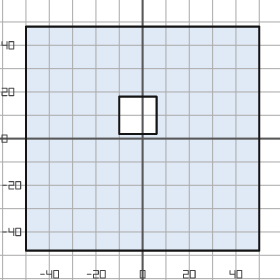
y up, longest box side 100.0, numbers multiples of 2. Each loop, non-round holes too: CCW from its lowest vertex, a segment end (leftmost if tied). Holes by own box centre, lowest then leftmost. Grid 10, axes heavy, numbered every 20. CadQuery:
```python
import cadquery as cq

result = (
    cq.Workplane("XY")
    .moveTo(-50.0, -48.0)
    .lineTo(50.0, -48.0)
    .lineTo(50.0, 48.0)
    .lineTo(-50.0, 48.0)
    .close()
    .moveTo(-10.0, 2.0)
    .lineTo(6.0, 2.0)
    .lineTo(6.0, 18.0)
    .lineTo(-10.0, 18.0)
    .close()
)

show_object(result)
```